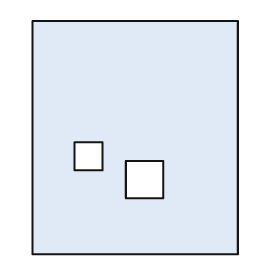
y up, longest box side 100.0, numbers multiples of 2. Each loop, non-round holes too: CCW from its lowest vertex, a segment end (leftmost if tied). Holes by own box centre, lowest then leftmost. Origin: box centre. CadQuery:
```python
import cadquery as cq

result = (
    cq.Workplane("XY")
    .moveTo(-44.0, -50.0)
    .lineTo(44.0, -50.0)
    .lineTo(44.0, 50.0)
    .lineTo(-44.0, 50.0)
    .close()
    .moveTo(-4.0, -26.0)
    .lineTo(12.0, -26.0)
    .lineTo(12.0, -10.0)
    .lineTo(-4.0, -10.0)
    .close()
    .moveTo(-26.0, -14.0)
    .lineTo(-14.0, -14.0)
    .lineTo(-14.0, -2.0)
    .lineTo(-26.0, -2.0)
    .close()
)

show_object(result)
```